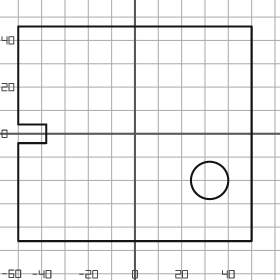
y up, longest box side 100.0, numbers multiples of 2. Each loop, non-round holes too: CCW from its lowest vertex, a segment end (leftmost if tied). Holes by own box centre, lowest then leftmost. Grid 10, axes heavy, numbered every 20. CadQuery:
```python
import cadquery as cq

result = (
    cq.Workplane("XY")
    .moveTo(-50.0, -46.0)
    .lineTo(50.0, -46.0)
    .lineTo(50.0, 46.0)
    .lineTo(-50.0, 46.0)
    .lineTo(-50.0, 4.0)
    .lineTo(-38.0, 4.0)
    .lineTo(-38.0, -4.0)
    .lineTo(-50.0, -4.0)
    .close()
    .moveTo(32.0, -20.0)
    .circle(8.0)
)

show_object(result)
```